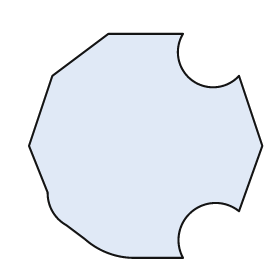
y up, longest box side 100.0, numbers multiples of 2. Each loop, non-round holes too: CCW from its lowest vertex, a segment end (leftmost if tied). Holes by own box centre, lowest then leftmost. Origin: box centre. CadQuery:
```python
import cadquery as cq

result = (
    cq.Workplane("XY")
    .moveTo(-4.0, -48.0)
    .lineTo(16.0, -48.0)
    .threePointArc((20.0, -28.0), (40.0, -28.0))
    .lineTo(50.0, 0.0)
    .lineTo(40.0, 30.0)
    .threePointArc((20.0, 28.0), (16.0, 48.0))
    .lineTo(-16.0, 48.0)
    .lineTo(-40.0, 30.0)
    .lineTo(-50.0, 0.0)
    .lineTo(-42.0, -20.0)
    .threePointArc((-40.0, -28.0), (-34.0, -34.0))
    .lineTo(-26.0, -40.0)
    .threePointArc((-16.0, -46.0), (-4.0, -48.0))
    .close()
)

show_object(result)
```